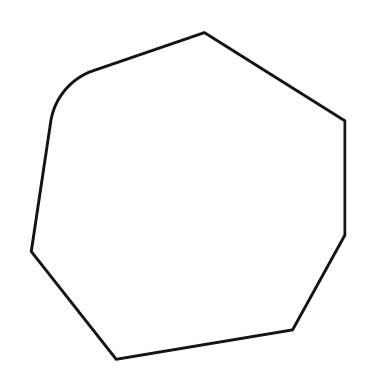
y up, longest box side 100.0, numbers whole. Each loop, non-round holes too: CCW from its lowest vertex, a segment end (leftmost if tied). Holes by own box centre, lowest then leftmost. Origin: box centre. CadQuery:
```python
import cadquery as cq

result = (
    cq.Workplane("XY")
    .moveTo(-22.0, -50.0)
    .lineTo(32.0, -41.0)
    .lineTo(48.0, -12.0)
    .lineTo(48.0, 23.0)
    .lineTo(5.0, 50.0)
    .lineTo(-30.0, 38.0)
    .threePointArc((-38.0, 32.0), (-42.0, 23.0))
    .lineTo(-48.0, -17.0)
    .close()
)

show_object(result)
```